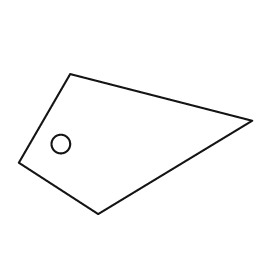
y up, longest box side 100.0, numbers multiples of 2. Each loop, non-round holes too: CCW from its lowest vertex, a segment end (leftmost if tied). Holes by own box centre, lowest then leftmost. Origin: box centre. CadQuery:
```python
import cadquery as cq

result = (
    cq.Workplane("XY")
    .moveTo(-16.0, -30.0)
    .lineTo(50.0, 10.0)
    .lineTo(-28.0, 30.0)
    .lineTo(-50.0, -8.0)
    .close()
    .moveTo(-32.0, 0.0)
    .circle(4.0)
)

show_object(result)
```